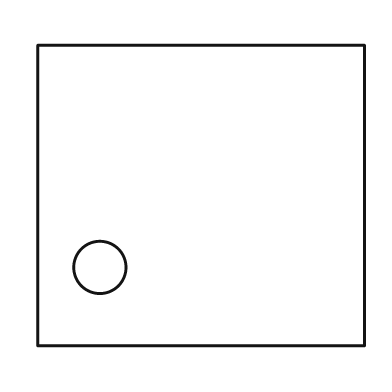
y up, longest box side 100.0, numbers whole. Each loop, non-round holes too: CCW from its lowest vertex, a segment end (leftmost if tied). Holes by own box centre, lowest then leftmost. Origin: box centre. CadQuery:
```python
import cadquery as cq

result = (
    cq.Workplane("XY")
    .moveTo(-50.0, -46.0)
    .lineTo(50.0, -46.0)
    .lineTo(50.0, 46.0)
    .lineTo(-50.0, 46.0)
    .close()
    .moveTo(-31.0, -22.0)
    .circle(8.0)
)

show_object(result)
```